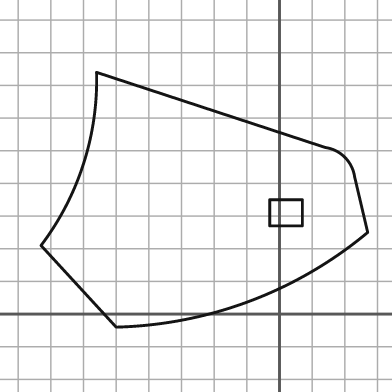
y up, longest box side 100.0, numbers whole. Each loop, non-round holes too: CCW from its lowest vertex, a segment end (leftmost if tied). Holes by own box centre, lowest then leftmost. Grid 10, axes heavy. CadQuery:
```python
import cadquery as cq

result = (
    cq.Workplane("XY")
    .moveTo(-50.0, -4.0)
    .threePointArc((-9.0, 4.0), (27.0, 25.0))
    .lineTo(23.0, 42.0)
    .threePointArc((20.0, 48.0), (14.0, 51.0))
    .lineTo(-56.0, 74.0)
    .threePointArc((-60.0, 46.0), (-73.0, 21.0))
    .close()
    .moveTo(-3.0, 27.0)
    .lineTo(7.0, 27.0)
    .lineTo(7.0, 35.0)
    .lineTo(-3.0, 35.0)
    .close()
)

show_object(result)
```